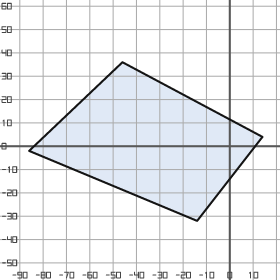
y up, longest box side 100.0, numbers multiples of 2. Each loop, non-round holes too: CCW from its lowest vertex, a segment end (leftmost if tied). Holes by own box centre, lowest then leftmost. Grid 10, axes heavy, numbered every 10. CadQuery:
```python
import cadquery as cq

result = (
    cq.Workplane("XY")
    .moveTo(-14.0, -32.0)
    .lineTo(14.0, 4.0)
    .lineTo(-46.0, 36.0)
    .lineTo(-86.0, -2.0)
    .close()
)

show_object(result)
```